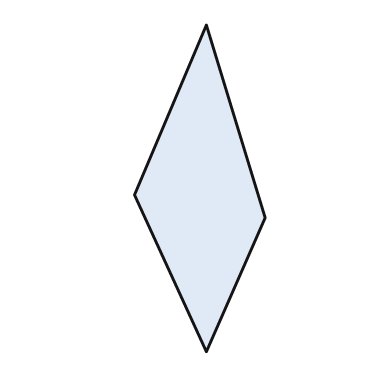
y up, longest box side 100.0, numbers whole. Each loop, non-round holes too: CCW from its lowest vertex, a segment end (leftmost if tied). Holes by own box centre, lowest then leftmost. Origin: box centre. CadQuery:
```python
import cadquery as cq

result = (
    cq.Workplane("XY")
    .moveTo(2.0, -50.0)
    .lineTo(20.0, -9.0)
    .lineTo(2.0, 50.0)
    .lineTo(-20.0, -2.0)
    .close()
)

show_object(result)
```